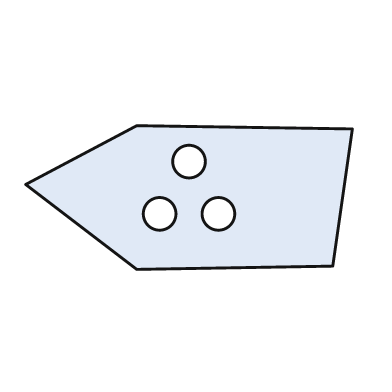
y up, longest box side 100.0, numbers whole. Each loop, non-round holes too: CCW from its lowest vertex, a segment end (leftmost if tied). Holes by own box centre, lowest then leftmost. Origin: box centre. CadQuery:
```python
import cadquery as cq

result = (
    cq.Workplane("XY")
    .moveTo(-16.0, -22.0)
    .lineTo(44.0, -21.0)
    .lineTo(50.0, 21.0)
    .lineTo(-16.0, 22.0)
    .lineTo(-50.0, 4.0)
    .close()
    .moveTo(-9.0, -5.0)
    .circle(5.0)
    .moveTo(9.0, -5.0)
    .circle(5.0)
    .moveTo(0.0, 11.0)
    .circle(5.0)
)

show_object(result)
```